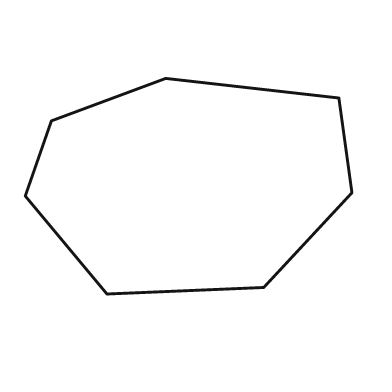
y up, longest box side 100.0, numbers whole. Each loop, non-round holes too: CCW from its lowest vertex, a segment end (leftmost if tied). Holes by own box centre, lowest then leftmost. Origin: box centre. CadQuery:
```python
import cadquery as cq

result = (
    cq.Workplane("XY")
    .moveTo(-25.0, -33.0)
    .lineTo(23.0, -31.0)
    .lineTo(50.0, -2.0)
    .lineTo(46.0, 27.0)
    .lineTo(-7.0, 33.0)
    .lineTo(-42.0, 20.0)
    .lineTo(-50.0, -3.0)
    .close()
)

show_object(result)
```